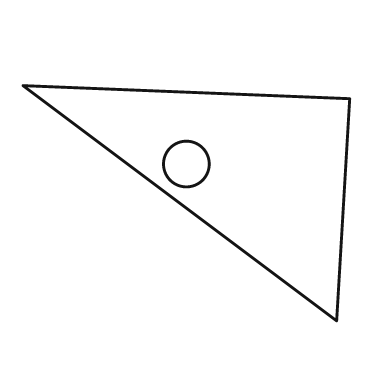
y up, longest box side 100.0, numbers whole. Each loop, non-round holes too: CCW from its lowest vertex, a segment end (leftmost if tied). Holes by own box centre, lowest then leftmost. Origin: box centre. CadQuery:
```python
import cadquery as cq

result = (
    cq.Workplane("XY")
    .moveTo(46.0, -36.0)
    .lineTo(50.0, 32.0)
    .lineTo(-50.0, 36.0)
    .close()
    .moveTo(0.0, 12.0)
    .circle(7.0)
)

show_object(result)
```